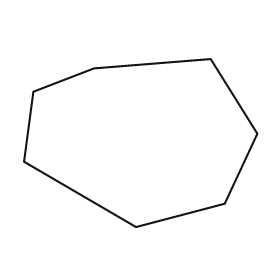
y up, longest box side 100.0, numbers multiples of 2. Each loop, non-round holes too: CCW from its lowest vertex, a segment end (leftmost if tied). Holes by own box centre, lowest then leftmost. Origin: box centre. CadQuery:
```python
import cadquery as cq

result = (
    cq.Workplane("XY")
    .moveTo(-2.0, -36.0)
    .lineTo(36.0, -26.0)
    .lineTo(50.0, 4.0)
    .lineTo(30.0, 36.0)
    .lineTo(-20.0, 32.0)
    .lineTo(-46.0, 22.0)
    .lineTo(-50.0, -8.0)
    .close()
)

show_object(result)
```